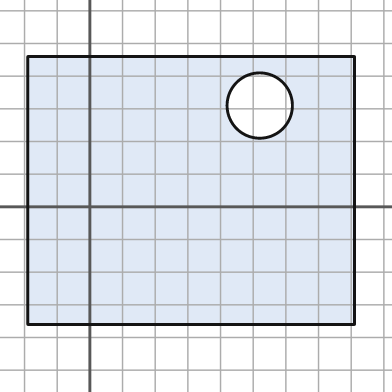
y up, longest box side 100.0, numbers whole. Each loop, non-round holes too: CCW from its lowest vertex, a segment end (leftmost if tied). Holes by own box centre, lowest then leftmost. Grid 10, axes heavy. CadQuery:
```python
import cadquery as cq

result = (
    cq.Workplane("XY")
    .moveTo(-19.0, -36.0)
    .lineTo(81.0, -36.0)
    .lineTo(81.0, 46.0)
    .lineTo(-19.0, 46.0)
    .close()
    .moveTo(52.0, 31.0)
    .circle(10.0)
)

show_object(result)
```